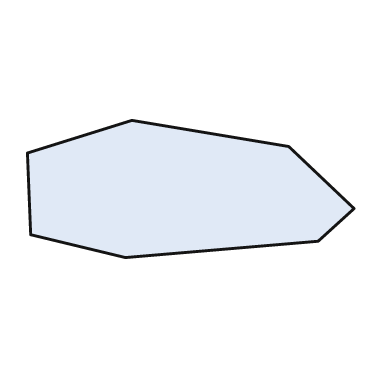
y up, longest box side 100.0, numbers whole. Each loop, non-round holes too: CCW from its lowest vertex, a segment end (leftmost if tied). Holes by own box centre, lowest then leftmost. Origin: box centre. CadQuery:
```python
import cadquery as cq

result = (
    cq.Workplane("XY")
    .moveTo(-20.0, -21.0)
    .lineTo(39.0, -16.0)
    .lineTo(50.0, -6.0)
    .lineTo(30.0, 13.0)
    .lineTo(-18.0, 21.0)
    .lineTo(-50.0, 11.0)
    .lineTo(-49.0, -14.0)
    .close()
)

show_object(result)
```